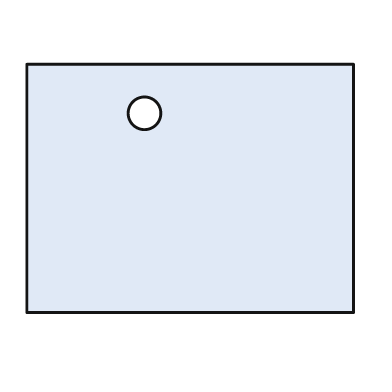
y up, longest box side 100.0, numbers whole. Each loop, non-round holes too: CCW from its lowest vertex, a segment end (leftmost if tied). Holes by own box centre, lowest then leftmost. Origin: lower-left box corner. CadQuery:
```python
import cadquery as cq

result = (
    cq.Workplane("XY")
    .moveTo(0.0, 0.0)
    .lineTo(100.0, 0.0)
    .lineTo(100.0, 76.0)
    .lineTo(0.0, 76.0)
    .close()
    .moveTo(36.0, 61.0)
    .circle(5.0)
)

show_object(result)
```